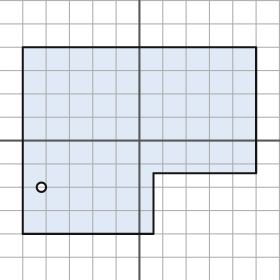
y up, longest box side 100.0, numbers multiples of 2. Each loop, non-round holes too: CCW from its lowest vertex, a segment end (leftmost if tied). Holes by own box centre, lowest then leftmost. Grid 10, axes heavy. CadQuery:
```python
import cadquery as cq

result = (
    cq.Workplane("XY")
    .moveTo(-50.0, -40.0)
    .lineTo(6.0, -40.0)
    .lineTo(6.0, -14.0)
    .lineTo(50.0, -14.0)
    .lineTo(50.0, 40.0)
    .lineTo(-50.0, 40.0)
    .close()
    .moveTo(-42.0, -20.0)
    .circle(2.0)
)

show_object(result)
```